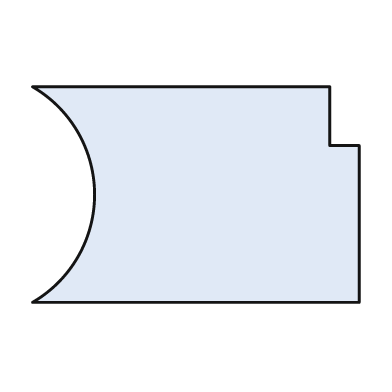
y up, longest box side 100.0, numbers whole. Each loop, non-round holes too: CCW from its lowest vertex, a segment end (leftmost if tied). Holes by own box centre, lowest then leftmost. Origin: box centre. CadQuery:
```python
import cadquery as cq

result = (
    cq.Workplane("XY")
    .moveTo(-50.0, -33.0)
    .lineTo(50.0, -33.0)
    .lineTo(50.0, 15.0)
    .lineTo(41.0, 15.0)
    .lineTo(41.0, 33.0)
    .lineTo(-50.0, 33.0)
    .threePointArc((-31.0, 0.0), (-50.0, -33.0))
    .close()
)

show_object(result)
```